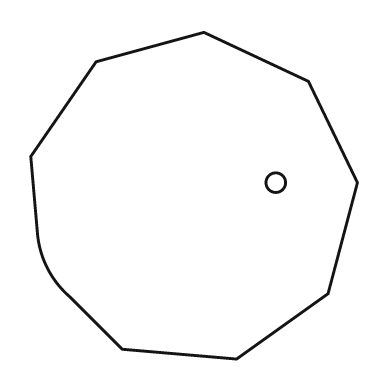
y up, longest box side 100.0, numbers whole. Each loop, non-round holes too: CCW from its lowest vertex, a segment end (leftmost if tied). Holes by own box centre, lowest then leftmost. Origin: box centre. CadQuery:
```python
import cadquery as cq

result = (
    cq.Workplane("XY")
    .moveTo(13.0, -50.0)
    .lineTo(41.0, -30.0)
    .lineTo(50.0, 4.0)
    .lineTo(35.0, 35.0)
    .lineTo(3.0, 50.0)
    .lineTo(-30.0, 41.0)
    .lineTo(-50.0, 12.0)
    .lineTo(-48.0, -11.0)
    .threePointArc((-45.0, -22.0), (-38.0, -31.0))
    .lineTo(-22.0, -47.0)
    .close()
    .moveTo(25.0, 4.0)
    .circle(3.0)
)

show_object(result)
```